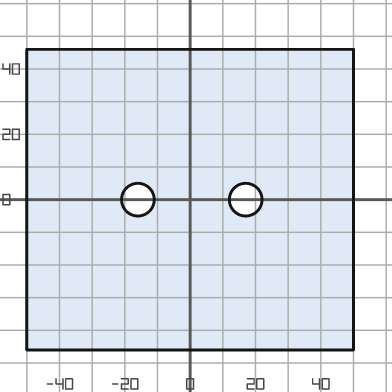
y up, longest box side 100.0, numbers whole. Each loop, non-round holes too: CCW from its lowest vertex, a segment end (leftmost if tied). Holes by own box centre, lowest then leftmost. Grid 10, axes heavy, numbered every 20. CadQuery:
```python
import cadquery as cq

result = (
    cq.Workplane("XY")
    .moveTo(-50.0, -46.0)
    .lineTo(50.0, -46.0)
    .lineTo(50.0, 46.0)
    .lineTo(-50.0, 46.0)
    .close()
    .moveTo(-16.0, 0.0)
    .circle(5.0)
    .moveTo(17.0, 0.0)
    .circle(5.0)
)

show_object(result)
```